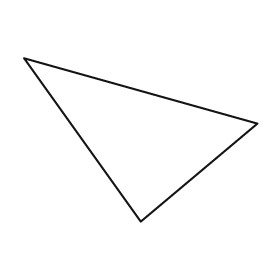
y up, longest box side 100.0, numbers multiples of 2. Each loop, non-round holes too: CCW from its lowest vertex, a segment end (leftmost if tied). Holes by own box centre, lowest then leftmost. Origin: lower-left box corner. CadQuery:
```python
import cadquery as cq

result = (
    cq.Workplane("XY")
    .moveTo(50.0, 0.0)
    .lineTo(100.0, 42.0)
    .lineTo(0.0, 70.0)
    .close()
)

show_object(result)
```